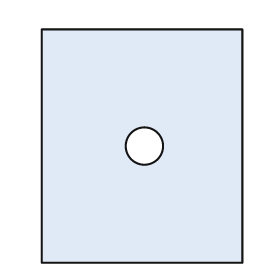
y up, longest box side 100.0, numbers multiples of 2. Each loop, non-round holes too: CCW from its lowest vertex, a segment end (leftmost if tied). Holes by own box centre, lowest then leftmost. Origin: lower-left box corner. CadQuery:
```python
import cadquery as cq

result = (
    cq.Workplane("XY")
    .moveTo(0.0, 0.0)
    .lineTo(86.0, 0.0)
    .lineTo(86.0, 100.0)
    .lineTo(0.0, 100.0)
    .close()
    .moveTo(44.0, 50.0)
    .circle(8.0)
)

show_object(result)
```